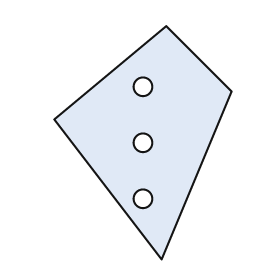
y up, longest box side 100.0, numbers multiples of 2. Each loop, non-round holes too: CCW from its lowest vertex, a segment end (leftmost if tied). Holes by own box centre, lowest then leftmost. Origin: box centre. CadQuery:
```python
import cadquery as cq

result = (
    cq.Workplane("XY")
    .moveTo(8.0, -50.0)
    .lineTo(38.0, 22.0)
    .lineTo(10.0, 50.0)
    .lineTo(-38.0, 10.0)
    .close()
    .moveTo(0.0, -24.0)
    .circle(4.0)
    .moveTo(0.0, 0.0)
    .circle(4.0)
    .moveTo(0.0, 24.0)
    .circle(4.0)
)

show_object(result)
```